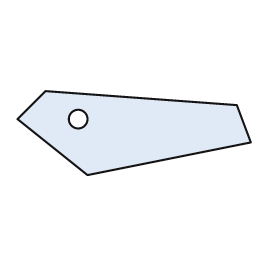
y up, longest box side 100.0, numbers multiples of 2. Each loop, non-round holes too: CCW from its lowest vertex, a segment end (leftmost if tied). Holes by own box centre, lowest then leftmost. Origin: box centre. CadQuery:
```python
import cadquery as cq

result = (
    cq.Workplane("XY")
    .moveTo(-20.0, -18.0)
    .lineTo(50.0, -4.0)
    .lineTo(44.0, 12.0)
    .lineTo(-38.0, 18.0)
    .lineTo(-50.0, 6.0)
    .close()
    .moveTo(-24.0, 6.0)
    .circle(4.0)
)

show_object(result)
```